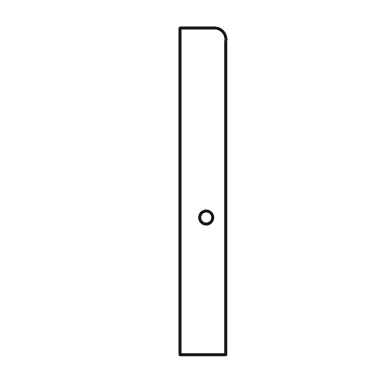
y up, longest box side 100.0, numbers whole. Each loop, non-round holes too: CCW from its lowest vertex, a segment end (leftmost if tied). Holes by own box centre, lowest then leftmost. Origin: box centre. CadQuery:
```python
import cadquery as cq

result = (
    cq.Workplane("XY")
    .moveTo(-7.0, -50.0)
    .lineTo(7.0, -50.0)
    .lineTo(7.0, 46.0)
    .threePointArc((6.0, 49.0), (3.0, 50.0))
    .lineTo(-7.0, 50.0)
    .close()
    .moveTo(1.0, -8.0)
    .circle(2.0)
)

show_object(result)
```